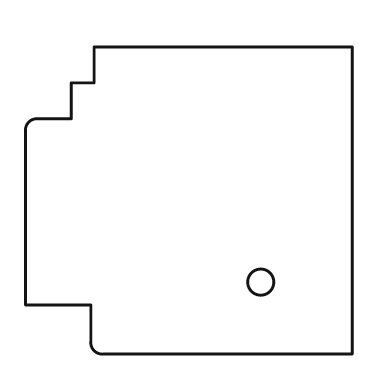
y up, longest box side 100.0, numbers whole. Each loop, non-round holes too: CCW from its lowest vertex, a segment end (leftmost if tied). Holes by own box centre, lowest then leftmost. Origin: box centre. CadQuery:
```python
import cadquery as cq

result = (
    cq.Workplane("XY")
    .moveTo(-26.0, -47.0)
    .lineTo(50.0, -47.0)
    .lineTo(50.0, 47.0)
    .lineTo(-29.0, 47.0)
    .lineTo(-29.0, 36.0)
    .lineTo(-36.0, 36.0)
    .lineTo(-36.0, 25.0)
    .lineTo(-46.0, 25.0)
    .threePointArc((-49.0, 24.0), (-50.0, 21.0))
    .lineTo(-50.0, -32.0)
    .lineTo(-30.0, -32.0)
    .lineTo(-30.0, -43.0)
    .threePointArc((-29.0, -46.0), (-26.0, -47.0))
    .close()
    .moveTo(22.0, -25.0)
    .circle(4.0)
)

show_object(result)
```